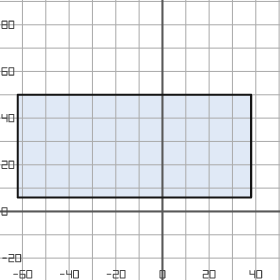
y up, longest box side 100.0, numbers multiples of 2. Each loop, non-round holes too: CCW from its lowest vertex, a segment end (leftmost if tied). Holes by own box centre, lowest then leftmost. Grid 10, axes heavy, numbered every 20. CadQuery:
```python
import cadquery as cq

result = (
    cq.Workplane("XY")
    .moveTo(-62.0, 6.0)
    .lineTo(38.0, 6.0)
    .lineTo(38.0, 50.0)
    .lineTo(-62.0, 50.0)
    .close()
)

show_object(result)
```